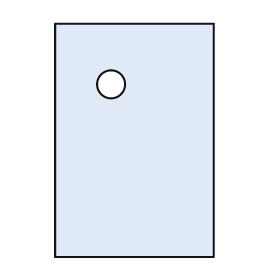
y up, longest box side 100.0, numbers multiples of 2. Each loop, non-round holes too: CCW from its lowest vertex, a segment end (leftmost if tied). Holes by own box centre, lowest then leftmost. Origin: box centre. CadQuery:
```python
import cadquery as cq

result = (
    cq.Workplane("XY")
    .moveTo(-34.0, -50.0)
    .lineTo(34.0, -50.0)
    .lineTo(34.0, 50.0)
    .lineTo(-34.0, 50.0)
    .close()
    .moveTo(-10.0, 24.0)
    .circle(6.0)
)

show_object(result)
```